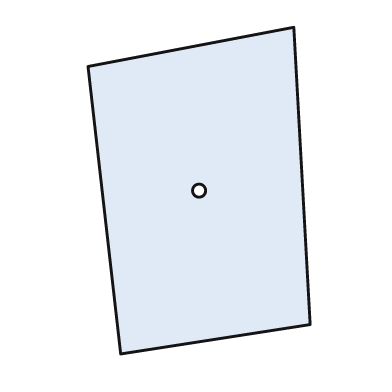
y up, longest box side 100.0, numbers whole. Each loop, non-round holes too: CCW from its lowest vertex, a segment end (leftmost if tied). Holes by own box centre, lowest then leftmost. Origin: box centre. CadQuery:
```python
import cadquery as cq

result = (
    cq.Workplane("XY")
    .moveTo(-24.0, -50.0)
    .lineTo(34.0, -41.0)
    .lineTo(29.0, 50.0)
    .lineTo(-34.0, 38.0)
    .close()
    .moveTo(0.0, 0.0)
    .circle(2.0)
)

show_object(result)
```